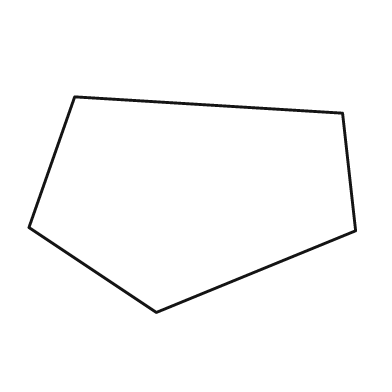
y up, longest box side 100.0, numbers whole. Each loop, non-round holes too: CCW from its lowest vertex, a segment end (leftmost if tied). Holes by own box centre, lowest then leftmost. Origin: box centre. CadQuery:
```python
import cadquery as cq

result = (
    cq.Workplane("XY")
    .moveTo(-11.0, -33.0)
    .lineTo(50.0, -8.0)
    .lineTo(46.0, 28.0)
    .lineTo(-36.0, 33.0)
    .lineTo(-50.0, -7.0)
    .close()
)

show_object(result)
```